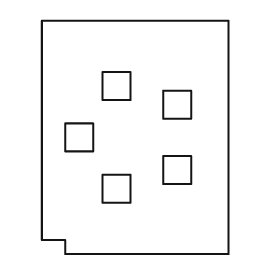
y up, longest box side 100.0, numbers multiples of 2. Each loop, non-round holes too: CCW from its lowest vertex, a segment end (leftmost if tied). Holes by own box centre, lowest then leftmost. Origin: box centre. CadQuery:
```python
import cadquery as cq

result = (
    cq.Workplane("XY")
    .moveTo(-30.0, -50.0)
    .lineTo(40.0, -50.0)
    .lineTo(40.0, 50.0)
    .lineTo(-40.0, 50.0)
    .lineTo(-40.0, -44.0)
    .lineTo(-30.0, -44.0)
    .close()
    .moveTo(-14.0, -28.0)
    .lineTo(-2.0, -28.0)
    .lineTo(-2.0, -16.0)
    .lineTo(-14.0, -16.0)
    .close()
    .moveTo(12.0, -20.0)
    .lineTo(24.0, -20.0)
    .lineTo(24.0, -8.0)
    .lineTo(12.0, -8.0)
    .close()
    .moveTo(-30.0, -6.0)
    .lineTo(-18.0, -6.0)
    .lineTo(-18.0, 6.0)
    .lineTo(-30.0, 6.0)
    .close()
    .moveTo(12.0, 8.0)
    .lineTo(24.0, 8.0)
    .lineTo(24.0, 20.0)
    .lineTo(12.0, 20.0)
    .close()
    .moveTo(-14.0, 16.0)
    .lineTo(-2.0, 16.0)
    .lineTo(-2.0, 28.0)
    .lineTo(-14.0, 28.0)
    .close()
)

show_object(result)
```